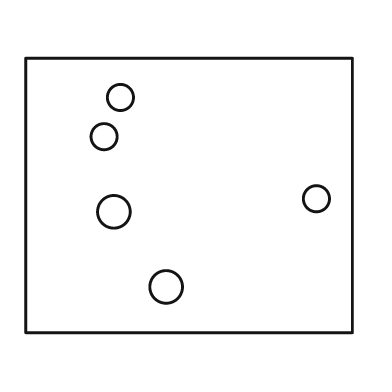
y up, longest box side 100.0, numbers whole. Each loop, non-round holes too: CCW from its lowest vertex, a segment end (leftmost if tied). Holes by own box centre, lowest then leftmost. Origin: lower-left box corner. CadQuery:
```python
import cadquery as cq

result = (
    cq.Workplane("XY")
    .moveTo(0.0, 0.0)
    .lineTo(100.0, 0.0)
    .lineTo(100.0, 84.0)
    .lineTo(0.0, 84.0)
    .close()
    .moveTo(43.0, 14.0)
    .circle(5.0)
    .moveTo(27.0, 37.0)
    .circle(5.0)
    .moveTo(89.0, 41.0)
    .circle(4.0)
    .moveTo(24.0, 60.0)
    .circle(4.0)
    .moveTo(29.0, 72.0)
    .circle(4.0)
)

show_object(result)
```